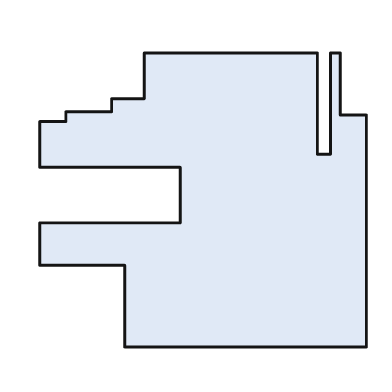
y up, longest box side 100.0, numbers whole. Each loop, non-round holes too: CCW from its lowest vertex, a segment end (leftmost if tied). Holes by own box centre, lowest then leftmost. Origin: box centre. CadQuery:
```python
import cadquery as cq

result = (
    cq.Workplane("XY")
    .moveTo(-24.0, -45.0)
    .lineTo(50.0, -45.0)
    .lineTo(50.0, 26.0)
    .lineTo(42.0, 26.0)
    .lineTo(42.0, 45.0)
    .lineTo(39.0, 45.0)
    .lineTo(39.0, 14.0)
    .lineTo(35.0, 14.0)
    .lineTo(35.0, 45.0)
    .lineTo(-18.0, 45.0)
    .lineTo(-18.0, 31.0)
    .lineTo(-28.0, 31.0)
    .lineTo(-28.0, 27.0)
    .lineTo(-42.0, 27.0)
    .lineTo(-42.0, 24.0)
    .lineTo(-50.0, 24.0)
    .lineTo(-50.0, 10.0)
    .lineTo(-7.0, 10.0)
    .lineTo(-7.0, -7.0)
    .lineTo(-50.0, -7.0)
    .lineTo(-50.0, -20.0)
    .lineTo(-24.0, -20.0)
    .close()
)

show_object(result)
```